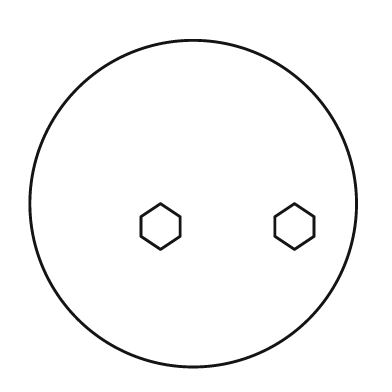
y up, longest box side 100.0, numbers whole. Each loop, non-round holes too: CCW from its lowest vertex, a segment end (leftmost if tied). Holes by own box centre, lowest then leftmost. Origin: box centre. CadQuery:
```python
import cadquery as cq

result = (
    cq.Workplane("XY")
    .moveTo(0.0, 0.0)
    .circle(50.0)
    .moveTo(-10.0, -14.0)
    .lineTo(-4.0, -10.0)
    .lineTo(-4.0, -4.0)
    .lineTo(-10.0, 0.0)
    .lineTo(-16.0, -4.0)
    .lineTo(-16.0, -10.0)
    .close()
    .moveTo(31.0, -14.0)
    .lineTo(37.0, -10.0)
    .lineTo(37.0, -4.0)
    .lineTo(31.0, 0.0)
    .lineTo(25.0, -4.0)
    .lineTo(25.0, -10.0)
    .close()
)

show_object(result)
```